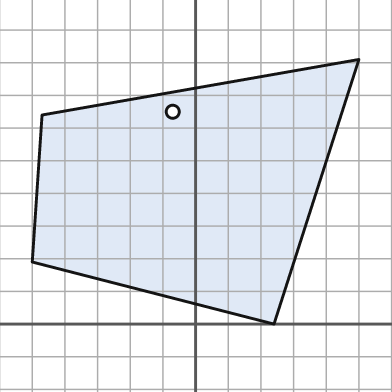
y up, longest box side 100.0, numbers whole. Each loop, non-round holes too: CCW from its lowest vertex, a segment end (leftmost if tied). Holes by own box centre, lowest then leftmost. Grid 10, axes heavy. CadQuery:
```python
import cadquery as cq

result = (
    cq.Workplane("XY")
    .moveTo(24.0, 0.0)
    .lineTo(50.0, 81.0)
    .lineTo(-47.0, 64.0)
    .lineTo(-50.0, 19.0)
    .close()
    .moveTo(-7.0, 65.0)
    .circle(2.0)
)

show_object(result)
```